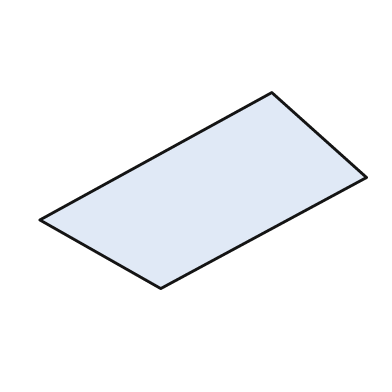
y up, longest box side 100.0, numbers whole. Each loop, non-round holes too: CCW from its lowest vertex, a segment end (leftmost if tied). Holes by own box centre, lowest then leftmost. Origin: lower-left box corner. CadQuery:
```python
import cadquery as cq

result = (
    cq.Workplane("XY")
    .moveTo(37.0, 0.0)
    .lineTo(100.0, 34.0)
    .lineTo(71.0, 60.0)
    .lineTo(0.0, 21.0)
    .close()
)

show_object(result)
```